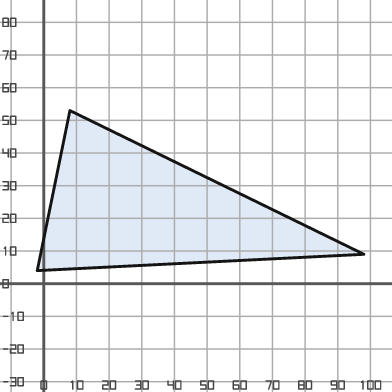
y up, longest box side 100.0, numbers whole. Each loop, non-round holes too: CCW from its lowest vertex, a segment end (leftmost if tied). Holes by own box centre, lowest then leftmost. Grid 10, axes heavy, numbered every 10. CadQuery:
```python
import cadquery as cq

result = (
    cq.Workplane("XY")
    .moveTo(-2.0, 4.0)
    .lineTo(98.0, 9.0)
    .lineTo(8.0, 53.0)
    .close()
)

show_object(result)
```